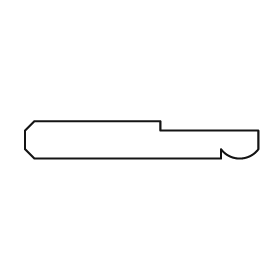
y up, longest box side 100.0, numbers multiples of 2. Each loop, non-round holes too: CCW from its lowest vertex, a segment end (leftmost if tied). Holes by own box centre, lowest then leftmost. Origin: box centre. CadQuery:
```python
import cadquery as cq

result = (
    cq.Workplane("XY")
    .moveTo(-46.0, -8.0)
    .lineTo(34.0, -8.0)
    .lineTo(34.0, -4.0)
    .threePointArc((42.0, -8.0), (50.0, -4.0))
    .lineTo(50.0, 4.0)
    .lineTo(8.0, 4.0)
    .lineTo(8.0, 8.0)
    .lineTo(-46.0, 8.0)
    .lineTo(-50.0, 4.0)
    .lineTo(-50.0, -4.0)
    .close()
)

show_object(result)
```